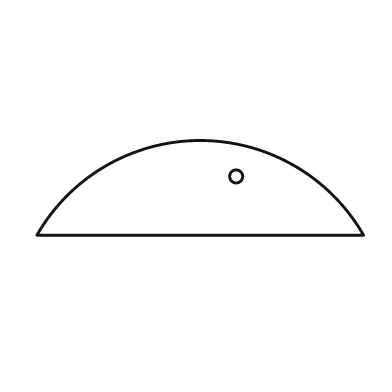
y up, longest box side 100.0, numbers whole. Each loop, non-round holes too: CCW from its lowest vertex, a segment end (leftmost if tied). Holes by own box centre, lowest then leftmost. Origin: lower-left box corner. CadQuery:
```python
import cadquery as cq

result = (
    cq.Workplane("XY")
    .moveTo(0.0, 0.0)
    .lineTo(100.0, 0.0)
    .threePointArc((50.0, 29.0), (0.0, 0.0))
    .close()
    .moveTo(61.0, 18.0)
    .circle(2.0)
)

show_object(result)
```